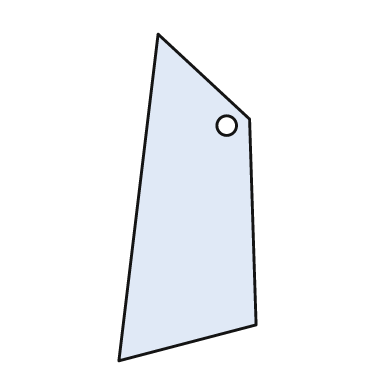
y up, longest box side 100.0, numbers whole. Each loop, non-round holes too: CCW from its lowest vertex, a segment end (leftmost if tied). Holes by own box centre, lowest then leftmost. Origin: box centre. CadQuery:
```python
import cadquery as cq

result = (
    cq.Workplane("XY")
    .moveTo(-21.0, -50.0)
    .lineTo(21.0, -39.0)
    .lineTo(19.0, 24.0)
    .lineTo(-9.0, 50.0)
    .close()
    .moveTo(12.0, 22.0)
    .circle(3.0)
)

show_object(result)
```